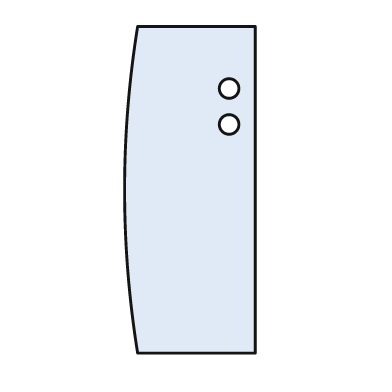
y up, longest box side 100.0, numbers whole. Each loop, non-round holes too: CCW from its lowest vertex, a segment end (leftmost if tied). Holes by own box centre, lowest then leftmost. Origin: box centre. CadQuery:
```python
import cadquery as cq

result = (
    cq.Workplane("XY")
    .moveTo(-16.0, -50.0)
    .lineTo(20.0, -50.0)
    .lineTo(20.0, 50.0)
    .lineTo(-16.0, 50.0)
    .threePointArc((-20.0, 0.0), (-16.0, -50.0))
    .close()
    .moveTo(12.0, 20.0)
    .circle(3.0)
    .moveTo(12.0, 31.0)
    .circle(3.0)
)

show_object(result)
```